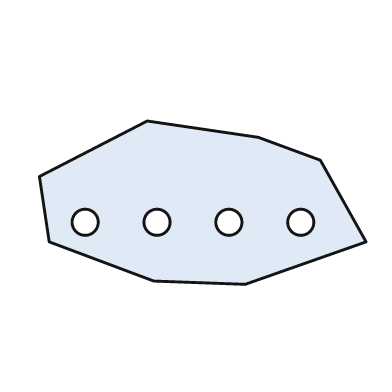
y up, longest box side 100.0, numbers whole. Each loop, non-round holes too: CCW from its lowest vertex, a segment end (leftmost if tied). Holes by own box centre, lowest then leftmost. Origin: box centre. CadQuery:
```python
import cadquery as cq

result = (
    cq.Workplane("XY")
    .moveTo(13.0, -25.0)
    .lineTo(50.0, -12.0)
    .lineTo(36.0, 13.0)
    .lineTo(17.0, 20.0)
    .lineTo(-17.0, 25.0)
    .lineTo(-50.0, 8.0)
    .lineTo(-47.0, -12.0)
    .lineTo(-15.0, -24.0)
    .close()
    .moveTo(-36.0, -6.0)
    .circle(4.0)
    .moveTo(-14.0, -6.0)
    .circle(4.0)
    .moveTo(8.0, -6.0)
    .circle(4.0)
    .moveTo(30.0, -6.0)
    .circle(4.0)
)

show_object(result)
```